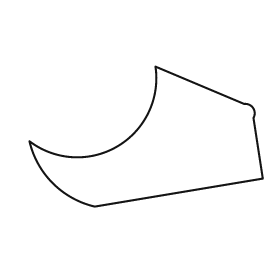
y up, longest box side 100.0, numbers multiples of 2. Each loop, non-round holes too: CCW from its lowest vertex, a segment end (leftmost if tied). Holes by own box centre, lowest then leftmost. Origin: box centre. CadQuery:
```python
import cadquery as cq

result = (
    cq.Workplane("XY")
    .moveTo(-22.0, -30.0)
    .lineTo(50.0, -18.0)
    .lineTo(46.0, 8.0)
    .threePointArc((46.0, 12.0), (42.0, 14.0))
    .lineTo(4.0, 30.0)
    .threePointArc((-12.0, -4.0), (-50.0, -2.0))
    .threePointArc((-40.0, -20.0), (-22.0, -30.0))
    .close()
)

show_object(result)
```